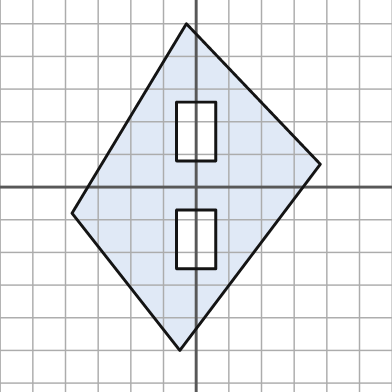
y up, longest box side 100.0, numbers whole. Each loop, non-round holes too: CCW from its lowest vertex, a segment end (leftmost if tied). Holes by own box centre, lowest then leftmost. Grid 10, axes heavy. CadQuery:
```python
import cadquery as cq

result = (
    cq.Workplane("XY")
    .moveTo(-5.0, -50.0)
    .lineTo(38.0, 7.0)
    .lineTo(-3.0, 50.0)
    .lineTo(-38.0, -8.0)
    .close()
    .moveTo(-6.0, -25.0)
    .lineTo(6.0, -25.0)
    .lineTo(6.0, -7.0)
    .lineTo(-6.0, -7.0)
    .close()
    .moveTo(-6.0, 8.0)
    .lineTo(6.0, 8.0)
    .lineTo(6.0, 26.0)
    .lineTo(-6.0, 26.0)
    .close()
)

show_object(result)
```